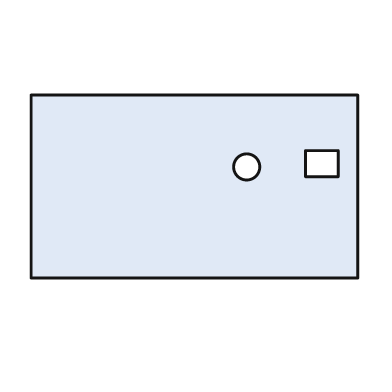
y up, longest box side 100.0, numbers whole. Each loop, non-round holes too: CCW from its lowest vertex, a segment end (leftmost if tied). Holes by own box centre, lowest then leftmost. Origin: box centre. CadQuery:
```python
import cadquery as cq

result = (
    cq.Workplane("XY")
    .moveTo(-50.0, -28.0)
    .lineTo(50.0, -28.0)
    .lineTo(50.0, 28.0)
    .lineTo(-50.0, 28.0)
    .close()
    .moveTo(16.0, 6.0)
    .circle(4.0)
    .moveTo(34.0, 3.0)
    .lineTo(44.0, 3.0)
    .lineTo(44.0, 11.0)
    .lineTo(34.0, 11.0)
    .close()
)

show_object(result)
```